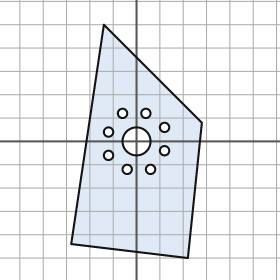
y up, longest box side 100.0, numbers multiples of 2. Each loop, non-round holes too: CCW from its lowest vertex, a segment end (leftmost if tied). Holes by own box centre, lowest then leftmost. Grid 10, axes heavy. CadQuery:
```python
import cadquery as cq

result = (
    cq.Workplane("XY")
    .moveTo(22.0, -50.0)
    .lineTo(28.0, 8.0)
    .lineTo(-14.0, 50.0)
    .lineTo(-28.0, -44.0)
    .close()
    .moveTo(-4.0, -12.0)
    .circle(2.0)
    .moveTo(6.0, -12.0)
    .circle(2.0)
    .moveTo(-12.0, -6.0)
    .circle(2.0)
    .moveTo(12.0, -4.0)
    .circle(2.0)
    .moveTo(0.0, 0.0)
    .circle(6.0)
    .moveTo(-12.0, 4.0)
    .circle(2.0)
    .moveTo(12.0, 6.0)
    .circle(2.0)
    .moveTo(-6.0, 12.0)
    .circle(2.0)
    .moveTo(4.0, 12.0)
    .circle(2.0)
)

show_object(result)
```